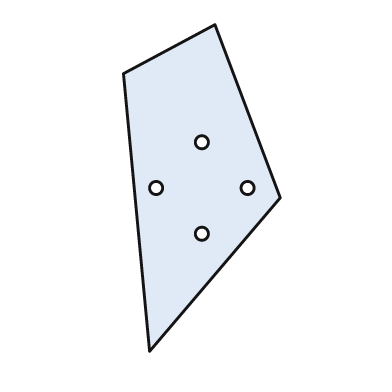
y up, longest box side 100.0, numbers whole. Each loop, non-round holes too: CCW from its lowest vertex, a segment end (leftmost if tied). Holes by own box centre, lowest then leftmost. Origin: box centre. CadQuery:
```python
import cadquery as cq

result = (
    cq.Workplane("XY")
    .moveTo(-16.0, -50.0)
    .lineTo(24.0, -3.0)
    .lineTo(4.0, 50.0)
    .lineTo(-24.0, 35.0)
    .close()
    .moveTo(0.0, -14.0)
    .circle(2.0)
    .moveTo(-14.0, 0.0)
    .circle(2.0)
    .moveTo(14.0, 0.0)
    .circle(2.0)
    .moveTo(0.0, 14.0)
    .circle(2.0)
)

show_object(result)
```